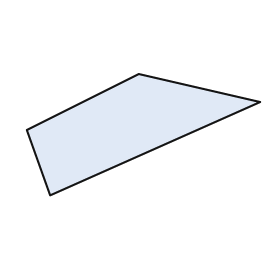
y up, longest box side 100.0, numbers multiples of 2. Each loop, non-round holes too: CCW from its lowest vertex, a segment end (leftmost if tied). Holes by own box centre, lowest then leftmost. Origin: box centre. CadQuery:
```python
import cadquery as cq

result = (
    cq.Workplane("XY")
    .moveTo(-40.0, -26.0)
    .lineTo(50.0, 14.0)
    .lineTo(-2.0, 26.0)
    .lineTo(-50.0, 2.0)
    .close()
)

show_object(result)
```